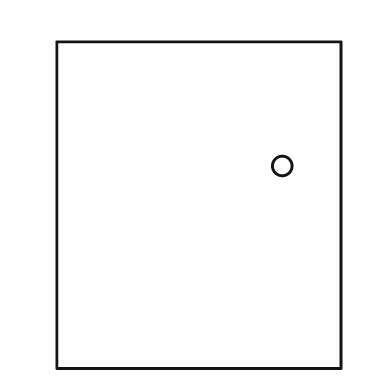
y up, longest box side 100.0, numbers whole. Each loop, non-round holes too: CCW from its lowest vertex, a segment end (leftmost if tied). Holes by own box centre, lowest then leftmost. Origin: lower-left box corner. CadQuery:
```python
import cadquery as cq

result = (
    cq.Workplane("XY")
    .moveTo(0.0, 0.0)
    .lineTo(87.0, 0.0)
    .lineTo(87.0, 100.0)
    .lineTo(0.0, 100.0)
    .close()
    .moveTo(69.0, 62.0)
    .circle(3.0)
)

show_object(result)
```